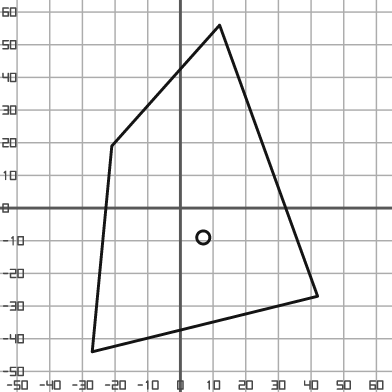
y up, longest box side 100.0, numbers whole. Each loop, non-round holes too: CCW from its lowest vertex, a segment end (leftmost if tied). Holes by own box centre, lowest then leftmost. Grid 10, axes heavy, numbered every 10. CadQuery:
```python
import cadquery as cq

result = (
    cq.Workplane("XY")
    .moveTo(-27.0, -44.0)
    .lineTo(42.0, -27.0)
    .lineTo(12.0, 56.0)
    .lineTo(-21.0, 19.0)
    .close()
    .moveTo(7.0, -9.0)
    .circle(2.0)
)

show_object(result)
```